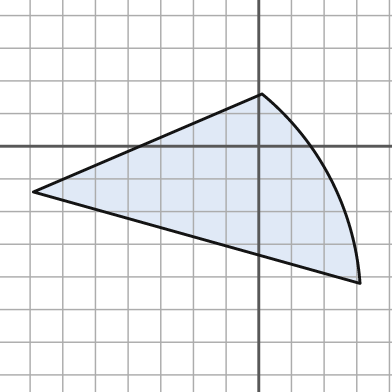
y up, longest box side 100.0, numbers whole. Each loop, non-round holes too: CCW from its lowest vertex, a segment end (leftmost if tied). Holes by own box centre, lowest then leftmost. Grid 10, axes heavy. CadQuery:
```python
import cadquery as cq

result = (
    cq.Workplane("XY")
    .moveTo(31.0, -42.0)
    .threePointArc((22.0, -10.0), (1.0, 16.0))
    .lineTo(-69.0, -14.0)
    .close()
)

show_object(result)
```